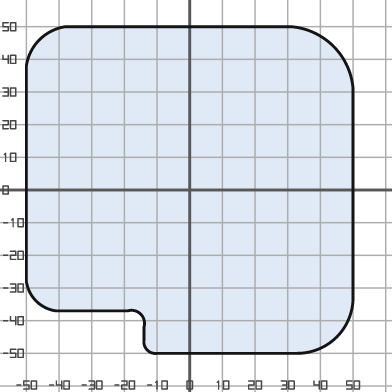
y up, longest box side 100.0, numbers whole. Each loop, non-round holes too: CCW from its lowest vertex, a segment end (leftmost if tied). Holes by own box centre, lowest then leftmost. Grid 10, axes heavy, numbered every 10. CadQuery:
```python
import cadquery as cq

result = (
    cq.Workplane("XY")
    .moveTo(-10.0, -50.0)
    .lineTo(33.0, -50.0)
    .threePointArc((45.0, -45.0), (50.0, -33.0))
    .lineTo(50.0, 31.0)
    .threePointArc((44.0, 44.0), (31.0, 50.0))
    .lineTo(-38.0, 50.0)
    .threePointArc((-46.0, 46.0), (-50.0, 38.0))
    .lineTo(-50.0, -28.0)
    .threePointArc((-47.0, -34.0), (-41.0, -37.0))
    .lineTo(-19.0, -37.0)
    .threePointArc((-15.0, -38.0), (-14.0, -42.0))
    .lineTo(-14.0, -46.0)
    .threePointArc((-13.0, -49.0), (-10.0, -50.0))
    .close()
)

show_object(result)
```